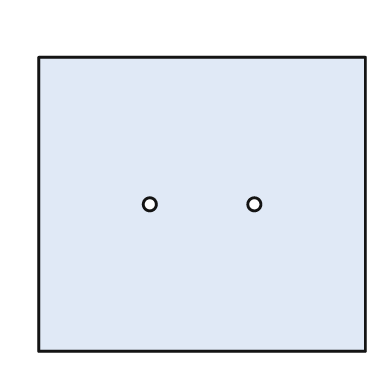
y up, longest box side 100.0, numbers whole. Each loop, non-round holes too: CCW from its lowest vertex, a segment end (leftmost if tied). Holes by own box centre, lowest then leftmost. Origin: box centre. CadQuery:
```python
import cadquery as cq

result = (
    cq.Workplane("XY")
    .moveTo(-50.0, -45.0)
    .lineTo(50.0, -45.0)
    .lineTo(50.0, 45.0)
    .lineTo(-50.0, 45.0)
    .close()
    .moveTo(-16.0, 0.0)
    .circle(2.0)
    .moveTo(16.0, 0.0)
    .circle(2.0)
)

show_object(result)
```